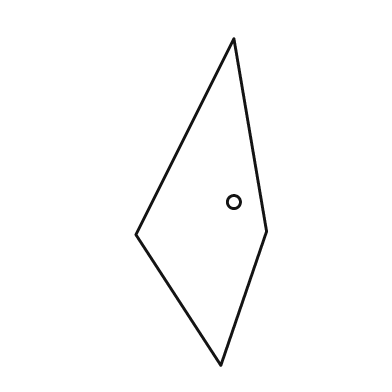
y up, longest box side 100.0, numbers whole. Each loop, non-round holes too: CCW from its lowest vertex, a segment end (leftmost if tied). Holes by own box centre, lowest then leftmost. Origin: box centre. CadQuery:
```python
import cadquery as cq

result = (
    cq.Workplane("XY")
    .moveTo(6.0, -50.0)
    .lineTo(20.0, -9.0)
    .lineTo(10.0, 50.0)
    .lineTo(-20.0, -10.0)
    .close()
    .moveTo(10.0, 0.0)
    .circle(2.0)
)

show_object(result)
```